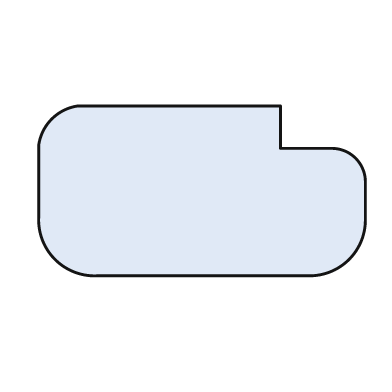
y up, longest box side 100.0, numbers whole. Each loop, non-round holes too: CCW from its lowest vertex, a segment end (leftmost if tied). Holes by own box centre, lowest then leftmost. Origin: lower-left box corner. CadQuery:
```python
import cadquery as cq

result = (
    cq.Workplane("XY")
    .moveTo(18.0, 0.0)
    .lineTo(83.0, 0.0)
    .threePointArc((95.0, 5.0), (100.0, 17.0))
    .lineTo(100.0, 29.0)
    .threePointArc((97.0, 36.0), (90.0, 39.0))
    .lineTo(74.0, 39.0)
    .lineTo(74.0, 52.0)
    .lineTo(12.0, 52.0)
    .threePointArc((4.0, 48.0), (0.0, 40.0))
    .lineTo(0.0, 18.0)
    .threePointArc((5.0, 5.0), (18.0, 0.0))
    .close()
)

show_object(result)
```